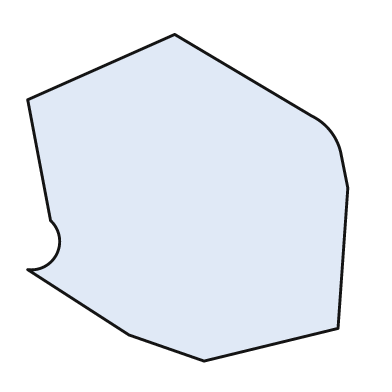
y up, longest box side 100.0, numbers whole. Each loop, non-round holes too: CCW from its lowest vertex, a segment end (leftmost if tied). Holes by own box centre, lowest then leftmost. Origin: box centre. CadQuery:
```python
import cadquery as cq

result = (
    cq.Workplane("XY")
    .moveTo(5.0, -50.0)
    .lineTo(46.0, -40.0)
    .lineTo(49.0, 3.0)
    .lineTo(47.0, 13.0)
    .threePointArc((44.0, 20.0), (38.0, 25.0))
    .lineTo(-4.0, 50.0)
    .lineTo(-49.0, 30.0)
    .lineTo(-42.0, -7.0)
    .threePointArc((-40.0, -17.0), (-49.0, -22.0))
    .lineTo(-18.0, -42.0)
    .close()
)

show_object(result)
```